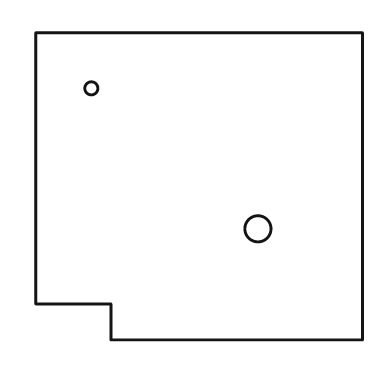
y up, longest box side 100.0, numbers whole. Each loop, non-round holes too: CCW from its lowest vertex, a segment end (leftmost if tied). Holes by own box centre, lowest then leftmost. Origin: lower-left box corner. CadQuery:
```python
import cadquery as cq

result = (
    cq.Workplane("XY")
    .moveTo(23.0, 0.0)
    .lineTo(100.0, 0.0)
    .lineTo(100.0, 94.0)
    .lineTo(0.0, 94.0)
    .lineTo(0.0, 11.0)
    .lineTo(23.0, 11.0)
    .close()
    .moveTo(68.0, 34.0)
    .circle(4.0)
    .moveTo(17.0, 77.0)
    .circle(2.0)
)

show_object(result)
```